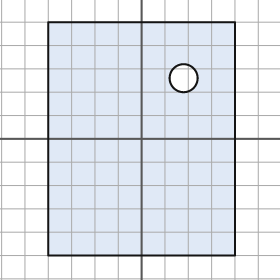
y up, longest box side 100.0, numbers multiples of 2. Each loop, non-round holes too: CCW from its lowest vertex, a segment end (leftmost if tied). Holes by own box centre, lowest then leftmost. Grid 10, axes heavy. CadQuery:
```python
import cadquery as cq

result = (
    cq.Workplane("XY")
    .moveTo(-40.0, -50.0)
    .lineTo(40.0, -50.0)
    .lineTo(40.0, 50.0)
    .lineTo(-40.0, 50.0)
    .close()
    .moveTo(18.0, 26.0)
    .circle(6.0)
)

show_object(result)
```